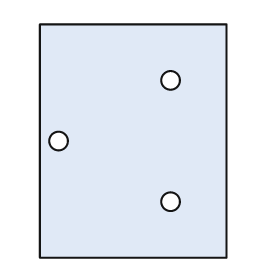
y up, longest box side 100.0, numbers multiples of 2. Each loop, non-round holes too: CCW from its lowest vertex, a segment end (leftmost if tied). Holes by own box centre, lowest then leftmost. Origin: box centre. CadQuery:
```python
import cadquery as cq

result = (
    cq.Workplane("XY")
    .moveTo(-40.0, -50.0)
    .lineTo(40.0, -50.0)
    .lineTo(40.0, 50.0)
    .lineTo(-40.0, 50.0)
    .close()
    .moveTo(16.0, -26.0)
    .circle(4.0)
    .moveTo(-32.0, 0.0)
    .circle(4.0)
    .moveTo(16.0, 26.0)
    .circle(4.0)
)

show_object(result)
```